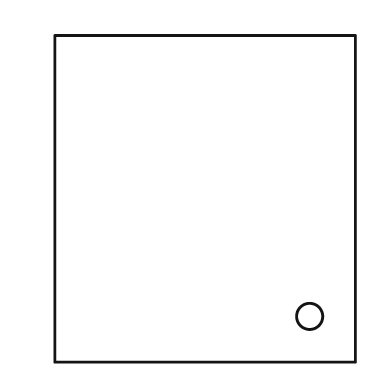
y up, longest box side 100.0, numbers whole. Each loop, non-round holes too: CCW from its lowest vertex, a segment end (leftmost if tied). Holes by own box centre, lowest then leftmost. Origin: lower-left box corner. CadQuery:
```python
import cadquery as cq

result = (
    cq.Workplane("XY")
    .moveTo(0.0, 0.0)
    .lineTo(92.0, 0.0)
    .lineTo(92.0, 100.0)
    .lineTo(0.0, 100.0)
    .close()
    .moveTo(78.0, 14.0)
    .circle(4.0)
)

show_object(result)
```